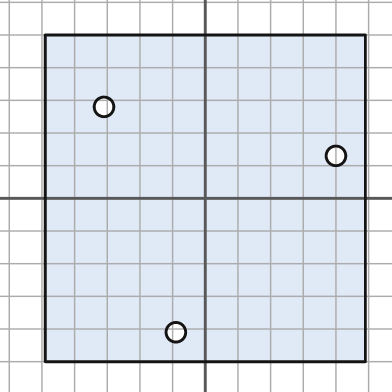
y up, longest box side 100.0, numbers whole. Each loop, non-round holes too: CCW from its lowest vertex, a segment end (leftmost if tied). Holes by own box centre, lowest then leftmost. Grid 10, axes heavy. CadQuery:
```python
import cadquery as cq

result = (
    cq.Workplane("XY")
    .moveTo(-49.0, -50.0)
    .lineTo(49.0, -50.0)
    .lineTo(49.0, 50.0)
    .lineTo(-49.0, 50.0)
    .close()
    .moveTo(-9.0, -41.0)
    .circle(3.0)
    .moveTo(40.0, 13.0)
    .circle(3.0)
    .moveTo(-31.0, 28.0)
    .circle(3.0)
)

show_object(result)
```